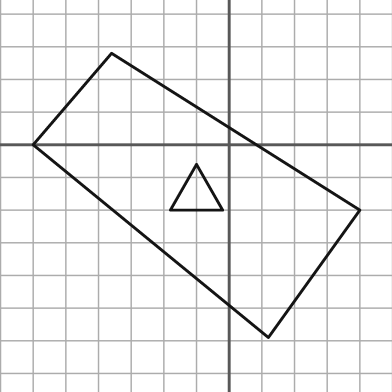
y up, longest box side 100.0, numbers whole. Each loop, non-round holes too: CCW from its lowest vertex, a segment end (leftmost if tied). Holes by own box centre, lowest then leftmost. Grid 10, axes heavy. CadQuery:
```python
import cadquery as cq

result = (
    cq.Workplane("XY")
    .moveTo(12.0, -59.0)
    .lineTo(40.0, -20.0)
    .lineTo(-36.0, 28.0)
    .lineTo(-60.0, 0.0)
    .close()
    .moveTo(-18.0, -20.0)
    .lineTo(-2.0, -20.0)
    .lineTo(-10.0, -6.0)
    .close()
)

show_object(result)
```